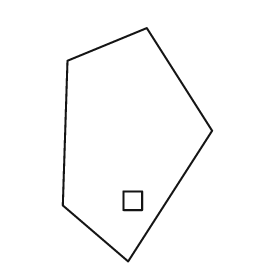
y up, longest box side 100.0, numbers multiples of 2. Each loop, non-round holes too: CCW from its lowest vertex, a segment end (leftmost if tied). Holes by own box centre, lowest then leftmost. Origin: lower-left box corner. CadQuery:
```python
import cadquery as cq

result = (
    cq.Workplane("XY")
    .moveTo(28.0, 0.0)
    .lineTo(64.0, 56.0)
    .lineTo(36.0, 100.0)
    .lineTo(2.0, 86.0)
    .lineTo(0.0, 24.0)
    .close()
    .moveTo(26.0, 22.0)
    .lineTo(34.0, 22.0)
    .lineTo(34.0, 30.0)
    .lineTo(26.0, 30.0)
    .close()
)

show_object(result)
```